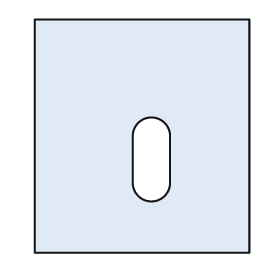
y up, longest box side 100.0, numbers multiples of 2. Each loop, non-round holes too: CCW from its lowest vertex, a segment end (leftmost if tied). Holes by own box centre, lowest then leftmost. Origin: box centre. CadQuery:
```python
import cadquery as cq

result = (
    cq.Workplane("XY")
    .moveTo(-46.0, -50.0)
    .lineTo(46.0, -50.0)
    .lineTo(46.0, 50.0)
    .lineTo(-46.0, 50.0)
    .close()
    .moveTo(-4.0, -20.0)
    .threePointArc((4.0, -28.0), (12.0, -20.0))
    .lineTo(12.0, 0.0)
    .threePointArc((4.0, 8.0), (-4.0, 0.0))
    .close()
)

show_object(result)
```